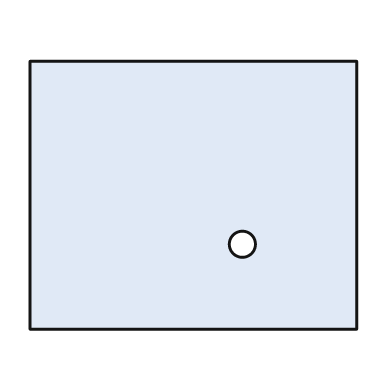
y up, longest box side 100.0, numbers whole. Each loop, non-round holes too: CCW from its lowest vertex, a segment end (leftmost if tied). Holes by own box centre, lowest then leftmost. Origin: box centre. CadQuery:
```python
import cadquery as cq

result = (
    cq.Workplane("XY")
    .moveTo(-50.0, -41.0)
    .lineTo(50.0, -41.0)
    .lineTo(50.0, 41.0)
    .lineTo(-50.0, 41.0)
    .close()
    .moveTo(15.0, -15.0)
    .circle(4.0)
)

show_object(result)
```